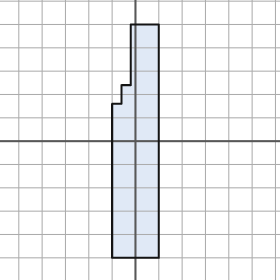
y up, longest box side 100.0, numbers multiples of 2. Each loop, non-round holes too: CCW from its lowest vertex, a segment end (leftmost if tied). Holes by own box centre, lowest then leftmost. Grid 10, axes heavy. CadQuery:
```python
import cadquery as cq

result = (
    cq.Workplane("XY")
    .moveTo(-10.0, -50.0)
    .lineTo(10.0, -50.0)
    .lineTo(10.0, 50.0)
    .lineTo(-2.0, 50.0)
    .lineTo(-2.0, 24.0)
    .lineTo(-6.0, 24.0)
    .lineTo(-6.0, 16.0)
    .lineTo(-10.0, 16.0)
    .close()
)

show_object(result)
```